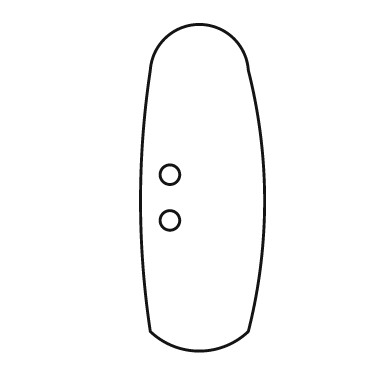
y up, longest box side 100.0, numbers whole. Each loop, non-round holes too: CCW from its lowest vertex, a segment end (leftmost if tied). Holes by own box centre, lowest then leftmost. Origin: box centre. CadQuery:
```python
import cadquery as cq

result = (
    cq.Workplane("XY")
    .moveTo(-16.0, -44.0)
    .threePointArc((-1.0, -50.0), (14.0, -44.0))
    .threePointArc((19.0, -4.0), (14.0, 36.0))
    .threePointArc((-1.0, 50.0), (-16.0, 36.0))
    .threePointArc((-19.0, -4.0), (-16.0, -44.0))
    .close()
    .moveTo(-10.0, -10.0)
    .circle(3.0)
    .moveTo(-10.0, 4.0)
    .circle(3.0)
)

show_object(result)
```